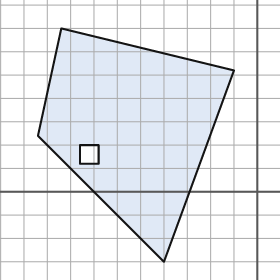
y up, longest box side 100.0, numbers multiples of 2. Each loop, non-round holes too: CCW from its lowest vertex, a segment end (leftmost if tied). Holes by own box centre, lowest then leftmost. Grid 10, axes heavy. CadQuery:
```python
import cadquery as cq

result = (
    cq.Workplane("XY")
    .moveTo(-40.0, -30.0)
    .lineTo(-10.0, 52.0)
    .lineTo(-84.0, 70.0)
    .lineTo(-94.0, 24.0)
    .close()
    .moveTo(-76.0, 12.0)
    .lineTo(-68.0, 12.0)
    .lineTo(-68.0, 20.0)
    .lineTo(-76.0, 20.0)
    .close()
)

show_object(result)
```